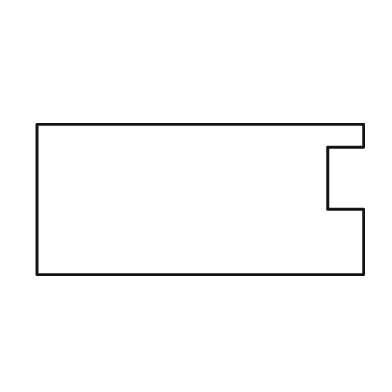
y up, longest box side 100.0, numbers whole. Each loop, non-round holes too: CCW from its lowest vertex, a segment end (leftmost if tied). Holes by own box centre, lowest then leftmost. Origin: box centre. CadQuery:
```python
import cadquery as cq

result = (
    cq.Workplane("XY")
    .moveTo(-50.0, -23.0)
    .lineTo(50.0, -23.0)
    .lineTo(50.0, -3.0)
    .lineTo(39.0, -3.0)
    .lineTo(39.0, 16.0)
    .lineTo(50.0, 16.0)
    .lineTo(50.0, 23.0)
    .lineTo(-50.0, 23.0)
    .close()
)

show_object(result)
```